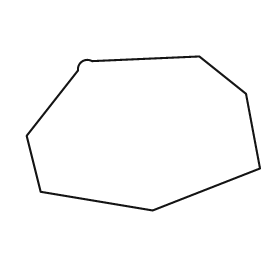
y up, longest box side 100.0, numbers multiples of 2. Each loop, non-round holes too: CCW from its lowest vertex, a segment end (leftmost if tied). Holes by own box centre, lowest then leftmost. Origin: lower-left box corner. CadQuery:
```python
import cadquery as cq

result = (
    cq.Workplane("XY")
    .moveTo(54.0, 0.0)
    .lineTo(100.0, 18.0)
    .lineTo(94.0, 50.0)
    .lineTo(74.0, 66.0)
    .lineTo(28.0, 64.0)
    .threePointArc((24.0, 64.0), (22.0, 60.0))
    .lineTo(0.0, 32.0)
    .lineTo(6.0, 8.0)
    .close()
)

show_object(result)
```